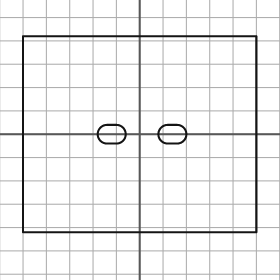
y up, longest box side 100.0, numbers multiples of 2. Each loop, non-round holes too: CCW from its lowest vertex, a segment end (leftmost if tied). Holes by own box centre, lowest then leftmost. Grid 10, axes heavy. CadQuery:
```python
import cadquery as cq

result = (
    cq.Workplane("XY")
    .moveTo(-50.0, -42.0)
    .lineTo(50.0, -42.0)
    .lineTo(50.0, 42.0)
    .lineTo(-50.0, 42.0)
    .close()
    .moveTo(-14.0, -4.0)
    .lineTo(-10.0, -4.0)
    .threePointArc((-6.0, 0.0), (-10.0, 4.0))
    .lineTo(-14.0, 4.0)
    .threePointArc((-18.0, 0.0), (-14.0, -4.0))
    .close()
    .moveTo(12.0, -4.0)
    .lineTo(16.0, -4.0)
    .threePointArc((20.0, 0.0), (16.0, 4.0))
    .lineTo(12.0, 4.0)
    .threePointArc((8.0, 0.0), (12.0, -4.0))
    .close()
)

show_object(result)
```